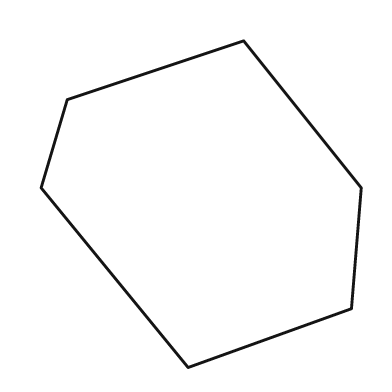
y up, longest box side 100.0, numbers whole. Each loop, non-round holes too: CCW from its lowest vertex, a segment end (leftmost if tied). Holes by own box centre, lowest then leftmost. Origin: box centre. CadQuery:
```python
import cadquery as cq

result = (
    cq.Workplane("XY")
    .moveTo(-4.0, -50.0)
    .lineTo(46.0, -32.0)
    .lineTo(49.0, 5.0)
    .lineTo(13.0, 50.0)
    .lineTo(-41.0, 32.0)
    .lineTo(-49.0, 5.0)
    .close()
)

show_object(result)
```